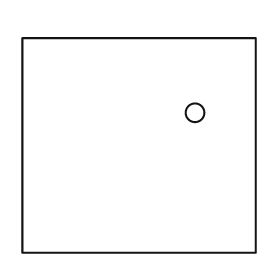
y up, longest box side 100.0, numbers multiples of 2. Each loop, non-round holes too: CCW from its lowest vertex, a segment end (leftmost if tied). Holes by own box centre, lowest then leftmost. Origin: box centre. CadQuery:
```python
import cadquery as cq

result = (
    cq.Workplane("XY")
    .moveTo(-50.0, -46.0)
    .lineTo(50.0, -46.0)
    .lineTo(50.0, 46.0)
    .lineTo(-50.0, 46.0)
    .close()
    .moveTo(24.0, 14.0)
    .circle(4.0)
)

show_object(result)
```